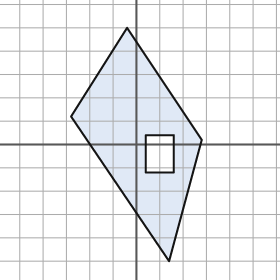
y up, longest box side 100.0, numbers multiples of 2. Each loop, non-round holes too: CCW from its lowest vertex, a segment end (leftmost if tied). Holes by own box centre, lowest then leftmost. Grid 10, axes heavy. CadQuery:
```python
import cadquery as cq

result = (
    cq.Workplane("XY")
    .moveTo(14.0, -50.0)
    .lineTo(28.0, 2.0)
    .lineTo(-4.0, 50.0)
    .lineTo(-28.0, 12.0)
    .close()
    .moveTo(4.0, -12.0)
    .lineTo(16.0, -12.0)
    .lineTo(16.0, 4.0)
    .lineTo(4.0, 4.0)
    .close()
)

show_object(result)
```